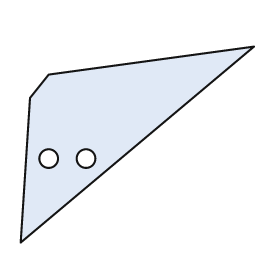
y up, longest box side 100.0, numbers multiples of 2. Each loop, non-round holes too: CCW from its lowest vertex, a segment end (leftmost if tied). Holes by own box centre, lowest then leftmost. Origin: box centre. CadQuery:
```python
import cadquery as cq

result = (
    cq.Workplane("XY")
    .moveTo(-50.0, -42.0)
    .lineTo(50.0, 42.0)
    .lineTo(-38.0, 30.0)
    .lineTo(-46.0, 20.0)
    .close()
    .moveTo(-38.0, -6.0)
    .circle(4.0)
    .moveTo(-22.0, -6.0)
    .circle(4.0)
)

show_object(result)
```